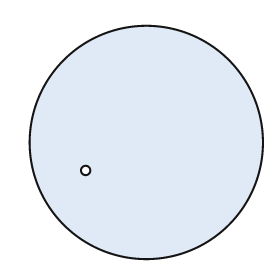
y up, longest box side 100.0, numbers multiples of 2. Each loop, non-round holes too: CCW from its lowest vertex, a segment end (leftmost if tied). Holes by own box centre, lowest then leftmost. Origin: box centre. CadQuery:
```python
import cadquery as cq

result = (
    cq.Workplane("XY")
    .moveTo(0.0, 0.0)
    .circle(50.0)
    .moveTo(-26.0, -12.0)
    .circle(2.0)
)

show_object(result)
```